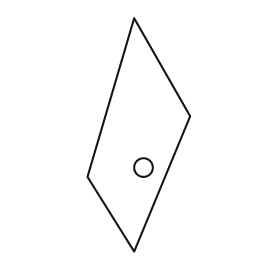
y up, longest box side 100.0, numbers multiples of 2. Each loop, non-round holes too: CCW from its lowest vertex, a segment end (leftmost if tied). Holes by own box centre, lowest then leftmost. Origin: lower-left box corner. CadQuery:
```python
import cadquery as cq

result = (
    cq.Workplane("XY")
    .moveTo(20.0, 0.0)
    .lineTo(44.0, 58.0)
    .lineTo(20.0, 100.0)
    .lineTo(0.0, 32.0)
    .close()
    .moveTo(24.0, 36.0)
    .circle(4.0)
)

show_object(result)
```